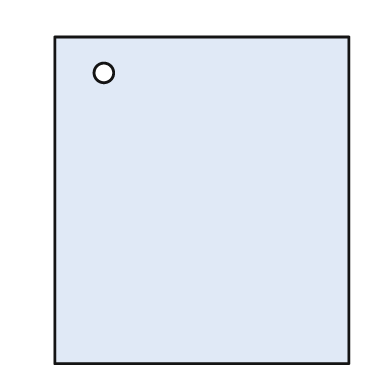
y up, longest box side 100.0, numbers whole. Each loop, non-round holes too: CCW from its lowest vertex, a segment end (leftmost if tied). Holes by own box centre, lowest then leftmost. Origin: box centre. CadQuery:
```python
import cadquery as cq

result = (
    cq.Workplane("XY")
    .moveTo(-45.0, -50.0)
    .lineTo(45.0, -50.0)
    .lineTo(45.0, 50.0)
    .lineTo(-45.0, 50.0)
    .close()
    .moveTo(-30.0, 39.0)
    .circle(3.0)
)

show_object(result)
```